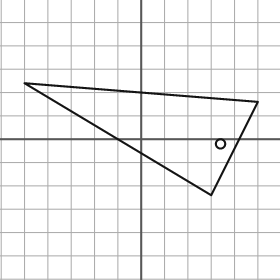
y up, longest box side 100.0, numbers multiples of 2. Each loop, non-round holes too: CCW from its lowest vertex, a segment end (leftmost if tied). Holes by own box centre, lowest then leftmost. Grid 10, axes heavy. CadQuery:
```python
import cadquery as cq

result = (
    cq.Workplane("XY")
    .moveTo(30.0, -24.0)
    .lineTo(50.0, 16.0)
    .lineTo(-50.0, 24.0)
    .close()
    .moveTo(34.0, -2.0)
    .circle(2.0)
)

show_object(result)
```